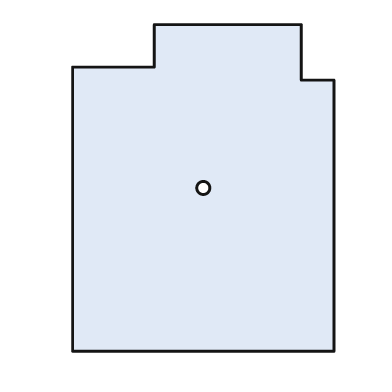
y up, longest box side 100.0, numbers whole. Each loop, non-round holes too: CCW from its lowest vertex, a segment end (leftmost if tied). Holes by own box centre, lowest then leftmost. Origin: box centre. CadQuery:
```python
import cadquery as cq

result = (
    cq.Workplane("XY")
    .moveTo(-40.0, -50.0)
    .lineTo(40.0, -50.0)
    .lineTo(40.0, 33.0)
    .lineTo(30.0, 33.0)
    .lineTo(30.0, 50.0)
    .lineTo(-15.0, 50.0)
    .lineTo(-15.0, 37.0)
    .lineTo(-40.0, 37.0)
    .close()
    .moveTo(0.0, 0.0)
    .circle(2.0)
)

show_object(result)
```